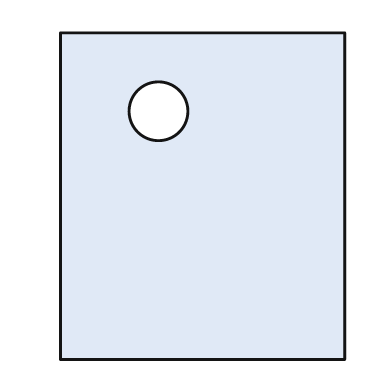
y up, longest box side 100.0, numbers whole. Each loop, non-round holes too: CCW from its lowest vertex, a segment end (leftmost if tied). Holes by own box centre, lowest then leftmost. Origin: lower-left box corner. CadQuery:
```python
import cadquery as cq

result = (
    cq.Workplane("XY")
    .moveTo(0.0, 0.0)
    .lineTo(87.0, 0.0)
    .lineTo(87.0, 100.0)
    .lineTo(0.0, 100.0)
    .close()
    .moveTo(30.0, 76.0)
    .circle(9.0)
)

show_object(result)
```